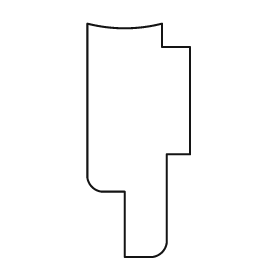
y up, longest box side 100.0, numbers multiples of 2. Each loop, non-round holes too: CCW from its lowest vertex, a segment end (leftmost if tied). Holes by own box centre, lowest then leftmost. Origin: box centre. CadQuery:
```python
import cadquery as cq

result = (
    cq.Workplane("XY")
    .moveTo(-6.0, -50.0)
    .lineTo(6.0, -50.0)
    .threePointArc((10.0, -48.0), (12.0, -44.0))
    .lineTo(12.0, -6.0)
    .lineTo(22.0, -6.0)
    .lineTo(22.0, 40.0)
    .lineTo(10.0, 40.0)
    .lineTo(10.0, 50.0)
    .threePointArc((-6.0, 48.0), (-22.0, 50.0))
    .lineTo(-22.0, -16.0)
    .threePointArc((-20.0, -20.0), (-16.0, -22.0))
    .lineTo(-6.0, -22.0)
    .close()
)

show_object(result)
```